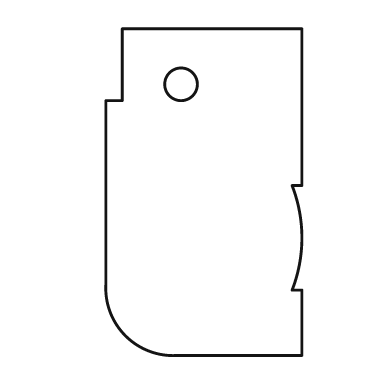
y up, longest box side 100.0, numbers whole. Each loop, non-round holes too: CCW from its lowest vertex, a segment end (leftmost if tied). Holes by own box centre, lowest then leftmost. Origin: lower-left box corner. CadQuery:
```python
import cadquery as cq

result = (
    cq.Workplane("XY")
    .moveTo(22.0, 0.0)
    .lineTo(60.0, 0.0)
    .lineTo(60.0, 20.0)
    .lineTo(57.0, 20.0)
    .threePointArc((60.0, 36.0), (57.0, 52.0))
    .lineTo(60.0, 52.0)
    .lineTo(60.0, 100.0)
    .lineTo(5.0, 100.0)
    .lineTo(5.0, 78.0)
    .lineTo(0.0, 78.0)
    .lineTo(0.0, 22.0)
    .threePointArc((6.0, 6.0), (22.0, 0.0))
    .close()
    .moveTo(23.0, 83.0)
    .circle(5.0)
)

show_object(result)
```